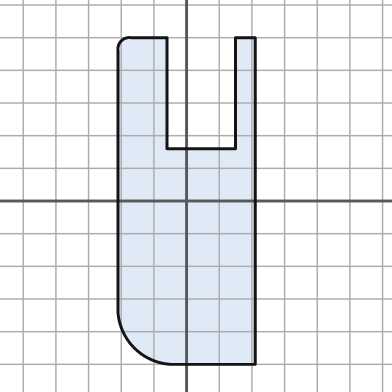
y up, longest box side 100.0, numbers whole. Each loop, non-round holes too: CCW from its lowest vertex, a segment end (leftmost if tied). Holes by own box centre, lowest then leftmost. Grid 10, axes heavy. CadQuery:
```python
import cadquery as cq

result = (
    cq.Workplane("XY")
    .moveTo(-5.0, -50.0)
    .lineTo(21.0, -50.0)
    .lineTo(21.0, 50.0)
    .lineTo(15.0, 50.0)
    .lineTo(15.0, 16.0)
    .lineTo(-6.0, 16.0)
    .lineTo(-6.0, 50.0)
    .lineTo(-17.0, 50.0)
    .threePointArc((-20.0, 49.0), (-21.0, 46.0))
    .lineTo(-21.0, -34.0)
    .threePointArc((-16.0, -45.0), (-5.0, -50.0))
    .close()
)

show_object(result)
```